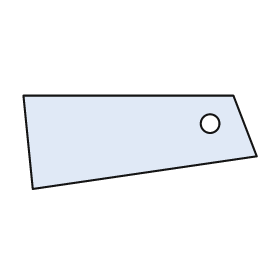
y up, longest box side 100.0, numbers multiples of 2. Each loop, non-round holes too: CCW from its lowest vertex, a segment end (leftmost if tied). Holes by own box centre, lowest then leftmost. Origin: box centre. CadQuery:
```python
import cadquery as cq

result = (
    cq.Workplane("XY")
    .moveTo(-46.0, -20.0)
    .lineTo(50.0, -6.0)
    .lineTo(40.0, 20.0)
    .lineTo(-50.0, 20.0)
    .close()
    .moveTo(30.0, 8.0)
    .circle(4.0)
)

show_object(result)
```